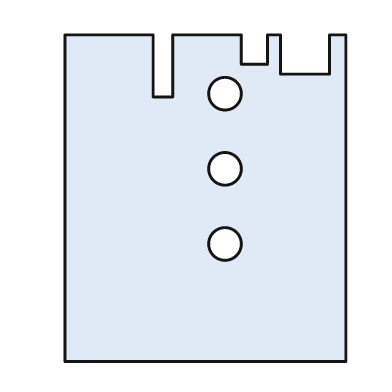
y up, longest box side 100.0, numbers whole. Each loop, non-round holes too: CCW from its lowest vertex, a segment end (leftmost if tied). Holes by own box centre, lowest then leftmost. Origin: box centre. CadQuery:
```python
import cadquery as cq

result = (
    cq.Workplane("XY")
    .moveTo(-43.0, -50.0)
    .lineTo(43.0, -50.0)
    .lineTo(43.0, 50.0)
    .lineTo(38.0, 50.0)
    .lineTo(38.0, 38.0)
    .lineTo(23.0, 38.0)
    .lineTo(23.0, 50.0)
    .lineTo(19.0, 50.0)
    .lineTo(19.0, 41.0)
    .lineTo(11.0, 41.0)
    .lineTo(11.0, 50.0)
    .lineTo(-10.0, 50.0)
    .lineTo(-10.0, 31.0)
    .lineTo(-16.0, 31.0)
    .lineTo(-16.0, 50.0)
    .lineTo(-43.0, 50.0)
    .close()
    .moveTo(6.0, -14.0)
    .circle(5.0)
    .moveTo(6.0, 9.0)
    .circle(5.0)
    .moveTo(6.0, 32.0)
    .circle(5.0)
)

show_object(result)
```